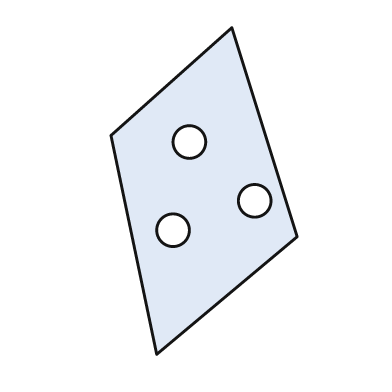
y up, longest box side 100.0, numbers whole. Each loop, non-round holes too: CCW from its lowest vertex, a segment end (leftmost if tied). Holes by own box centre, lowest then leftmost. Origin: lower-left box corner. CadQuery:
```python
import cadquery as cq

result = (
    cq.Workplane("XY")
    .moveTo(14.0, 0.0)
    .lineTo(57.0, 36.0)
    .lineTo(37.0, 100.0)
    .lineTo(0.0, 67.0)
    .close()
    .moveTo(19.0, 38.0)
    .circle(5.0)
    .moveTo(44.0, 47.0)
    .circle(5.0)
    .moveTo(24.0, 65.0)
    .circle(5.0)
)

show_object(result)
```